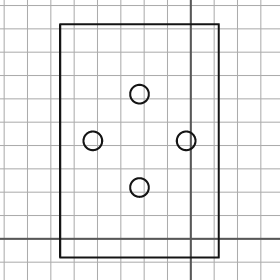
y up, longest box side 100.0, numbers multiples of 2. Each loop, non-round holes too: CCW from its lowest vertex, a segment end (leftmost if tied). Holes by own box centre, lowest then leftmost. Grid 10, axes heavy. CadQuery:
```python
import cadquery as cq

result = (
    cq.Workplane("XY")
    .moveTo(-56.0, -8.0)
    .lineTo(12.0, -8.0)
    .lineTo(12.0, 92.0)
    .lineTo(-56.0, 92.0)
    .close()
    .moveTo(-22.0, 22.0)
    .circle(4.0)
    .moveTo(-42.0, 42.0)
    .circle(4.0)
    .moveTo(-2.0, 42.0)
    .circle(4.0)
    .moveTo(-22.0, 62.0)
    .circle(4.0)
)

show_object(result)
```